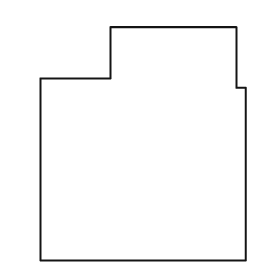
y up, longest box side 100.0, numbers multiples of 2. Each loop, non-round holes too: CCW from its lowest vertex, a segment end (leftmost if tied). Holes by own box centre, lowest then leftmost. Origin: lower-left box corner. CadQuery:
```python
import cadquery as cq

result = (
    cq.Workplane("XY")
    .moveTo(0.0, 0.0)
    .lineTo(88.0, 0.0)
    .lineTo(88.0, 74.0)
    .lineTo(84.0, 74.0)
    .lineTo(84.0, 100.0)
    .lineTo(30.0, 100.0)
    .lineTo(30.0, 78.0)
    .lineTo(0.0, 78.0)
    .close()
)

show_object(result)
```